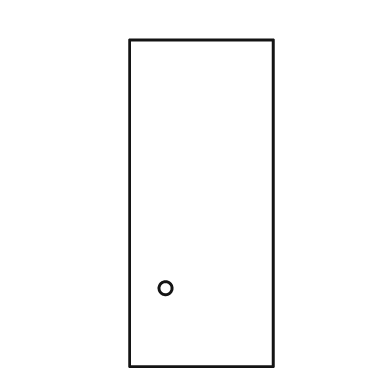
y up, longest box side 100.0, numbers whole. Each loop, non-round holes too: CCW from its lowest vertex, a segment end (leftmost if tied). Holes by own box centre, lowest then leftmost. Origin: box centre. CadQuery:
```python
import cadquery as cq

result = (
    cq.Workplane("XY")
    .moveTo(-22.0, -50.0)
    .lineTo(22.0, -50.0)
    .lineTo(22.0, 50.0)
    .lineTo(-22.0, 50.0)
    .close()
    .moveTo(-11.0, -26.0)
    .circle(2.0)
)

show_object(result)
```